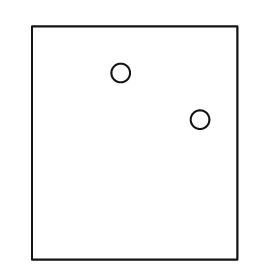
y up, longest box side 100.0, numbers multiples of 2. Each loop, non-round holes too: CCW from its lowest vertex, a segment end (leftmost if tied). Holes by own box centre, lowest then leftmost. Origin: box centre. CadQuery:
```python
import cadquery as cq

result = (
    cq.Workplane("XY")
    .moveTo(-44.0, -50.0)
    .lineTo(44.0, -50.0)
    .lineTo(44.0, 50.0)
    .lineTo(-44.0, 50.0)
    .close()
    .moveTo(28.0, 10.0)
    .circle(4.0)
    .moveTo(-6.0, 30.0)
    .circle(4.0)
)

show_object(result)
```